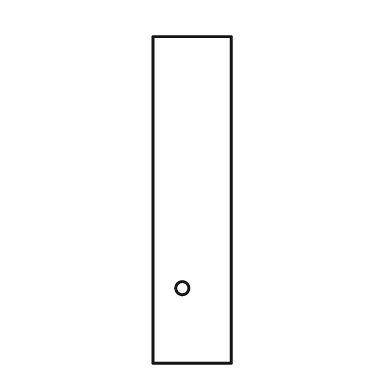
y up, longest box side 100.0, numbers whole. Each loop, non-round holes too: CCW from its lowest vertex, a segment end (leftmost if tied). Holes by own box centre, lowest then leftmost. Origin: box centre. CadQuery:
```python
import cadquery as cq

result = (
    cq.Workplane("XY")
    .moveTo(-12.0, -50.0)
    .lineTo(12.0, -50.0)
    .lineTo(12.0, 50.0)
    .lineTo(-12.0, 50.0)
    .close()
    .moveTo(-3.0, -27.0)
    .circle(2.0)
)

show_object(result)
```